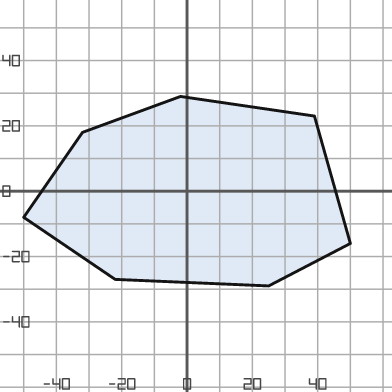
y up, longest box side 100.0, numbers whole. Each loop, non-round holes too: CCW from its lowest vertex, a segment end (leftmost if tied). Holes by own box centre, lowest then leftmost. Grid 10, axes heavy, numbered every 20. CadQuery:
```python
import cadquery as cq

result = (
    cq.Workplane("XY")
    .moveTo(25.0, -29.0)
    .lineTo(50.0, -16.0)
    .lineTo(39.0, 23.0)
    .lineTo(-2.0, 29.0)
    .lineTo(-32.0, 18.0)
    .lineTo(-50.0, -8.0)
    .lineTo(-22.0, -27.0)
    .close()
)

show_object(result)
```